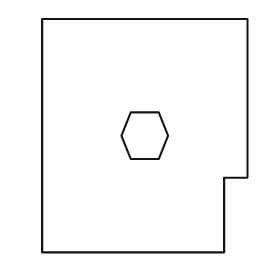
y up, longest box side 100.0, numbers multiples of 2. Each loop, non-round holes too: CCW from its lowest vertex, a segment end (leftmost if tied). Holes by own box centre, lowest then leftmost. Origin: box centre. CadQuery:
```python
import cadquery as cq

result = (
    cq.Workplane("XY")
    .moveTo(-44.0, -50.0)
    .lineTo(34.0, -50.0)
    .lineTo(34.0, -18.0)
    .lineTo(44.0, -18.0)
    .lineTo(44.0, 50.0)
    .lineTo(-44.0, 50.0)
    .close()
    .moveTo(-6.0, -10.0)
    .lineTo(6.0, -10.0)
    .lineTo(10.0, 0.0)
    .lineTo(6.0, 10.0)
    .lineTo(-6.0, 10.0)
    .lineTo(-10.0, 0.0)
    .close()
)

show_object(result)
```